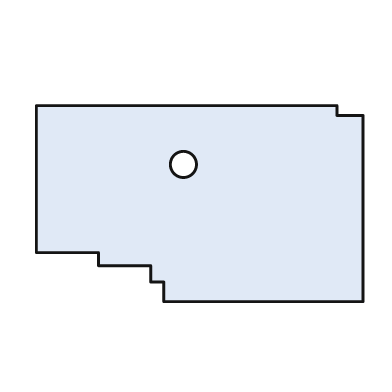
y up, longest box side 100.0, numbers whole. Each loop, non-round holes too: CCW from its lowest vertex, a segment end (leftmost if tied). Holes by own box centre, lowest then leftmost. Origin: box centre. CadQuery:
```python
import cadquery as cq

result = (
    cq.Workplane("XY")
    .moveTo(-11.0, -30.0)
    .lineTo(50.0, -30.0)
    .lineTo(50.0, 27.0)
    .lineTo(42.0, 27.0)
    .lineTo(42.0, 30.0)
    .lineTo(-50.0, 30.0)
    .lineTo(-50.0, -15.0)
    .lineTo(-31.0, -15.0)
    .lineTo(-31.0, -19.0)
    .lineTo(-15.0, -19.0)
    .lineTo(-15.0, -24.0)
    .lineTo(-11.0, -24.0)
    .close()
    .moveTo(-5.0, 12.0)
    .circle(4.0)
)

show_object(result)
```